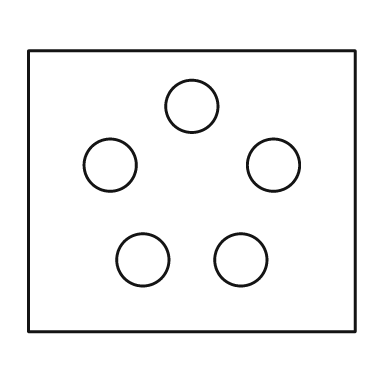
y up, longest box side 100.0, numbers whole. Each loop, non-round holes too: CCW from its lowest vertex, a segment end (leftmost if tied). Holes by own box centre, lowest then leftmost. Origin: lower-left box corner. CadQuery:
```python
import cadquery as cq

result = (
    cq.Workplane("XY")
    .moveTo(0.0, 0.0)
    .lineTo(100.0, 0.0)
    .lineTo(100.0, 86.0)
    .lineTo(0.0, 86.0)
    .close()
    .moveTo(35.0, 22.0)
    .circle(8.0)
    .moveTo(65.0, 22.0)
    .circle(8.0)
    .moveTo(25.0, 51.0)
    .circle(8.0)
    .moveTo(75.0, 51.0)
    .circle(8.0)
    .moveTo(50.0, 69.0)
    .circle(8.0)
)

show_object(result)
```